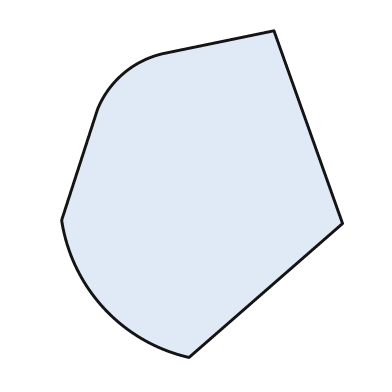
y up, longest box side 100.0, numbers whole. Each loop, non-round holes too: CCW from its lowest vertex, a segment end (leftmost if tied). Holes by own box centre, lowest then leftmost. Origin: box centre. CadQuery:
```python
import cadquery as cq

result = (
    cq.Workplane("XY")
    .moveTo(-4.0, -50.0)
    .lineTo(43.0, -9.0)
    .lineTo(22.0, 50.0)
    .lineTo(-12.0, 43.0)
    .threePointArc((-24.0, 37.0), (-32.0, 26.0))
    .lineTo(-43.0, -8.0)
    .threePointArc((-30.0, -35.0), (-4.0, -50.0))
    .close()
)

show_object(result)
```